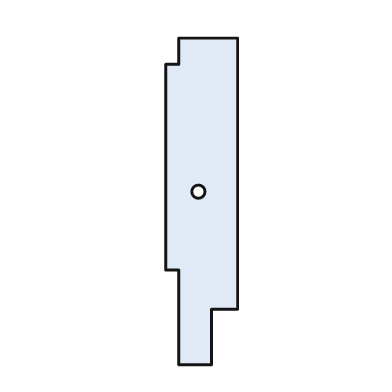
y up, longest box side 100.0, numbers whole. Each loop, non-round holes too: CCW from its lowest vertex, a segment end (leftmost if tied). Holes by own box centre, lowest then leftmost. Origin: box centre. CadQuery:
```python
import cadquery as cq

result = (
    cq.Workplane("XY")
    .moveTo(-7.0, -50.0)
    .lineTo(3.0, -50.0)
    .lineTo(3.0, -33.0)
    .lineTo(11.0, -33.0)
    .lineTo(11.0, 50.0)
    .lineTo(-7.0, 50.0)
    .lineTo(-7.0, 42.0)
    .lineTo(-11.0, 42.0)
    .lineTo(-11.0, -21.0)
    .lineTo(-7.0, -21.0)
    .close()
    .moveTo(-1.0, 3.0)
    .circle(2.0)
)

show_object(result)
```